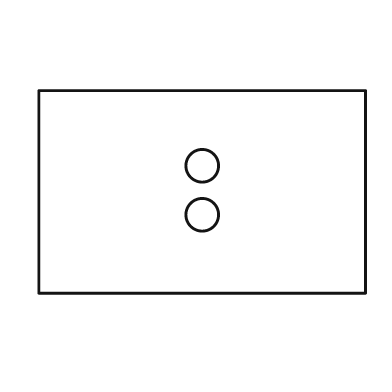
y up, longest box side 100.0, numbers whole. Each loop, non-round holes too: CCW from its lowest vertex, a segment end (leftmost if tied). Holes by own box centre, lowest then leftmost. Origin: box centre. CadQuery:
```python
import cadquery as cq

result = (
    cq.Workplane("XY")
    .moveTo(-50.0, -31.0)
    .lineTo(50.0, -31.0)
    .lineTo(50.0, 31.0)
    .lineTo(-50.0, 31.0)
    .close()
    .moveTo(0.0, -7.0)
    .circle(5.0)
    .moveTo(0.0, 8.0)
    .circle(5.0)
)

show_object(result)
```